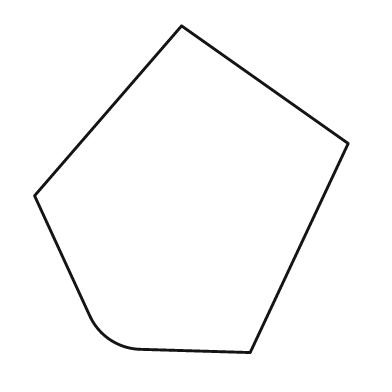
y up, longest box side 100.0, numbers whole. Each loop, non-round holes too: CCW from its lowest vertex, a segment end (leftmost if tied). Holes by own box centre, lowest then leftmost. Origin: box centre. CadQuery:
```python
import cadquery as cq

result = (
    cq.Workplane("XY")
    .moveTo(18.0, -50.0)
    .lineTo(48.0, 14.0)
    .lineTo(-3.0, 50.0)
    .lineTo(-48.0, -2.0)
    .lineTo(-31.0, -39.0)
    .threePointArc((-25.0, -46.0), (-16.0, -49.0))
    .close()
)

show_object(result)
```